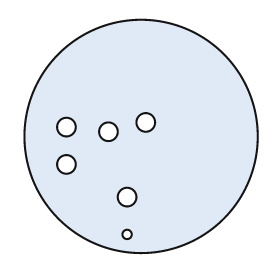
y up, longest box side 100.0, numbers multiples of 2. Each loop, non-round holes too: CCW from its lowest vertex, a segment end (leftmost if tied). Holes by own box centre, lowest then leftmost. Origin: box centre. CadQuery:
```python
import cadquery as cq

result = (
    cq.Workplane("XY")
    .moveTo(0.0, 0.0)
    .circle(50.0)
    .moveTo(-6.0, -42.0)
    .circle(2.0)
    .moveTo(-6.0, -26.0)
    .circle(4.0)
    .moveTo(-32.0, -12.0)
    .circle(4.0)
    .moveTo(-14.0, 2.0)
    .circle(4.0)
    .moveTo(-32.0, 4.0)
    .circle(4.0)
    .moveTo(2.0, 6.0)
    .circle(4.0)
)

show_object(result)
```